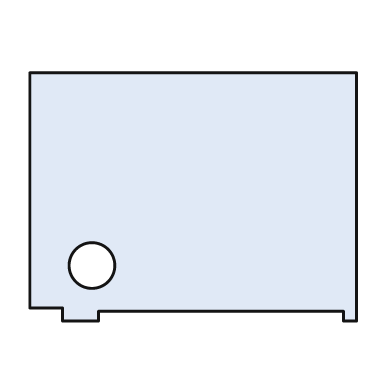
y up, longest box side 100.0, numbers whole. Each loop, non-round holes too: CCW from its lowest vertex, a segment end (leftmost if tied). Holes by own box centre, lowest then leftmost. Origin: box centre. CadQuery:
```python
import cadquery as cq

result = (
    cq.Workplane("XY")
    .moveTo(-40.0, -38.0)
    .lineTo(-29.0, -38.0)
    .lineTo(-29.0, -35.0)
    .lineTo(46.0, -35.0)
    .lineTo(46.0, -38.0)
    .lineTo(50.0, -38.0)
    .lineTo(50.0, 38.0)
    .lineTo(-50.0, 38.0)
    .lineTo(-50.0, -34.0)
    .lineTo(-40.0, -34.0)
    .close()
    .moveTo(-31.0, -21.0)
    .circle(7.0)
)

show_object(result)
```